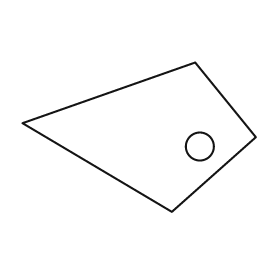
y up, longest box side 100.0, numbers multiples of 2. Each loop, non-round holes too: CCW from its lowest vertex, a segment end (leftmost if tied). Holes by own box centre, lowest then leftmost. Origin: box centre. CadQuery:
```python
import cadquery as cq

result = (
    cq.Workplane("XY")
    .moveTo(14.0, -32.0)
    .lineTo(50.0, 0.0)
    .lineTo(24.0, 32.0)
    .lineTo(-50.0, 6.0)
    .close()
    .moveTo(26.0, -4.0)
    .circle(6.0)
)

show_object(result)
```